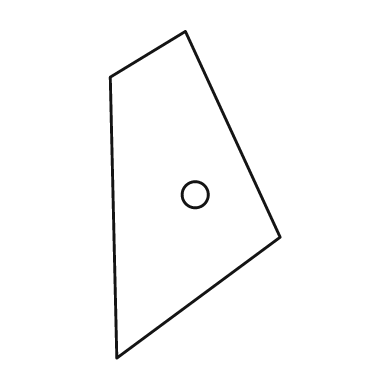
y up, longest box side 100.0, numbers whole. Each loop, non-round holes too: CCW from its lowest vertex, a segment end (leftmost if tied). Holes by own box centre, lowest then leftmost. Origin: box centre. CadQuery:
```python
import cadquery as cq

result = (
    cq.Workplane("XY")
    .moveTo(-24.0, -50.0)
    .lineTo(26.0, -13.0)
    .lineTo(-3.0, 50.0)
    .lineTo(-26.0, 36.0)
    .close()
    .moveTo(0.0, 0.0)
    .circle(4.0)
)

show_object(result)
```